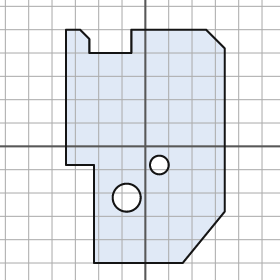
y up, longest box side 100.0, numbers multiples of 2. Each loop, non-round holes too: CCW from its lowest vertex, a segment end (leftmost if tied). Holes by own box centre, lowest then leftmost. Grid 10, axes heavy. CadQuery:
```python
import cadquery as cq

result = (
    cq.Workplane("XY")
    .moveTo(-22.0, -50.0)
    .lineTo(16.0, -50.0)
    .lineTo(34.0, -28.0)
    .lineTo(34.0, 42.0)
    .lineTo(26.0, 50.0)
    .lineTo(-6.0, 50.0)
    .lineTo(-6.0, 40.0)
    .lineTo(-24.0, 40.0)
    .lineTo(-24.0, 46.0)
    .lineTo(-28.0, 50.0)
    .lineTo(-34.0, 50.0)
    .lineTo(-34.0, -8.0)
    .lineTo(-22.0, -8.0)
    .close()
    .moveTo(-8.0, -22.0)
    .circle(6.0)
    .moveTo(6.0, -8.0)
    .circle(4.0)
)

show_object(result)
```